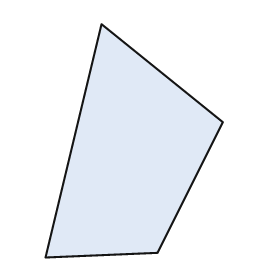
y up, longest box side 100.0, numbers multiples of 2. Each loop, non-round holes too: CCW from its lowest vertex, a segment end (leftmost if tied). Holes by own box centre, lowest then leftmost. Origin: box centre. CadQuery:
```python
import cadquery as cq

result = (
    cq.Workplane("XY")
    .moveTo(-38.0, -50.0)
    .lineTo(10.0, -48.0)
    .lineTo(38.0, 8.0)
    .lineTo(-14.0, 50.0)
    .close()
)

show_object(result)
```